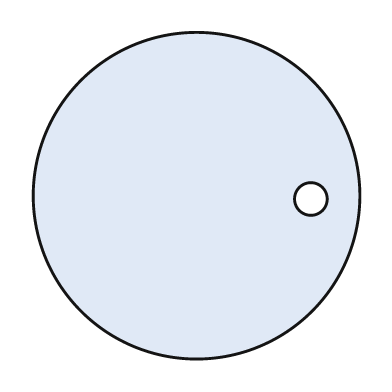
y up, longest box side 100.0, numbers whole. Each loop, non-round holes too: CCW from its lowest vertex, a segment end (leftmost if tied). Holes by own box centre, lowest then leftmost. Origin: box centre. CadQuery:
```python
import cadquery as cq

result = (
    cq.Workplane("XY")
    .moveTo(0.0, 0.0)
    .circle(50.0)
    .moveTo(35.0, -1.0)
    .circle(5.0)
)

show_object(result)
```